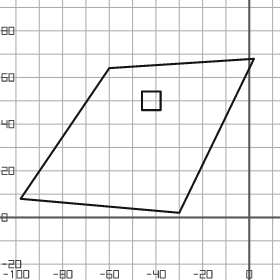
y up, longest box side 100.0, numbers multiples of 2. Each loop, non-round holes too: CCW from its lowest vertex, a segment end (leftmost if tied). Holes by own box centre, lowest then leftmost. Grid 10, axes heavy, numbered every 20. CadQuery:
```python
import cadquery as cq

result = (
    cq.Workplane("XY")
    .moveTo(-30.0, 2.0)
    .lineTo(2.0, 68.0)
    .lineTo(-60.0, 64.0)
    .lineTo(-98.0, 8.0)
    .close()
    .moveTo(-46.0, 46.0)
    .lineTo(-38.0, 46.0)
    .lineTo(-38.0, 54.0)
    .lineTo(-46.0, 54.0)
    .close()
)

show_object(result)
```